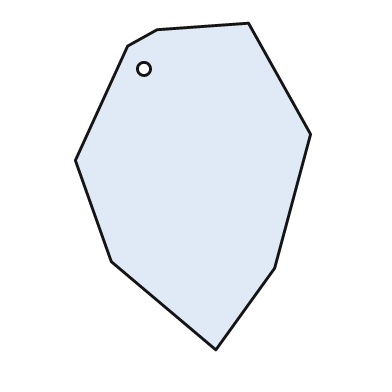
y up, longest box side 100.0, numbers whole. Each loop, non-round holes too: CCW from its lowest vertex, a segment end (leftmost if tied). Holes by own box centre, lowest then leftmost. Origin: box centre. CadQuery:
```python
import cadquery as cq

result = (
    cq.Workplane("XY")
    .moveTo(7.0, -50.0)
    .lineTo(25.0, -25.0)
    .lineTo(36.0, 16.0)
    .lineTo(17.0, 50.0)
    .lineTo(-11.0, 48.0)
    .lineTo(-20.0, 43.0)
    .lineTo(-36.0, 8.0)
    .lineTo(-25.0, -23.0)
    .close()
    .moveTo(-15.0, 36.0)
    .circle(2.0)
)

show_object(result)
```